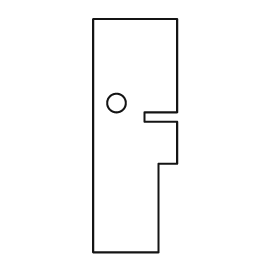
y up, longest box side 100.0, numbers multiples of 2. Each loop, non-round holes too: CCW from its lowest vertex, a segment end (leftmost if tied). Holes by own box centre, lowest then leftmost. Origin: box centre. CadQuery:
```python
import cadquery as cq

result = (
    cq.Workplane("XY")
    .moveTo(-18.0, -50.0)
    .lineTo(10.0, -50.0)
    .lineTo(10.0, -12.0)
    .lineTo(18.0, -12.0)
    .lineTo(18.0, 6.0)
    .lineTo(4.0, 6.0)
    .lineTo(4.0, 10.0)
    .lineTo(18.0, 10.0)
    .lineTo(18.0, 50.0)
    .lineTo(-18.0, 50.0)
    .close()
    .moveTo(-8.0, 14.0)
    .circle(4.0)
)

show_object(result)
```